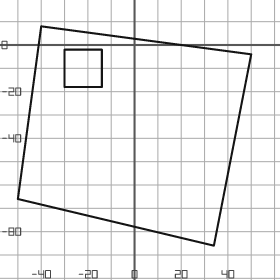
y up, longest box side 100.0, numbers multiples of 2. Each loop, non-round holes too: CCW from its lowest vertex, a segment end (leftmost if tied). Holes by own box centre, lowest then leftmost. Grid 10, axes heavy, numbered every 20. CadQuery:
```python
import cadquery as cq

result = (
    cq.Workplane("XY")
    .moveTo(34.0, -86.0)
    .lineTo(50.0, -4.0)
    .lineTo(-40.0, 8.0)
    .lineTo(-50.0, -66.0)
    .close()
    .moveTo(-30.0, -18.0)
    .lineTo(-14.0, -18.0)
    .lineTo(-14.0, -2.0)
    .lineTo(-30.0, -2.0)
    .close()
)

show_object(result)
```